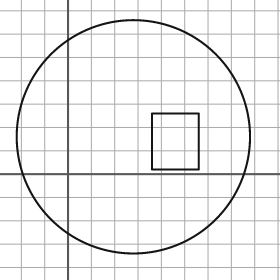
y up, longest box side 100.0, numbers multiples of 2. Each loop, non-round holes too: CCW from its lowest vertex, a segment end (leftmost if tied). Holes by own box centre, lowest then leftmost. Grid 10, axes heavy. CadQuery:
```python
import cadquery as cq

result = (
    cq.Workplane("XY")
    .moveTo(28.0, 16.0)
    .circle(50.0)
    .moveTo(36.0, 2.0)
    .lineTo(56.0, 2.0)
    .lineTo(56.0, 26.0)
    .lineTo(36.0, 26.0)
    .close()
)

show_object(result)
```